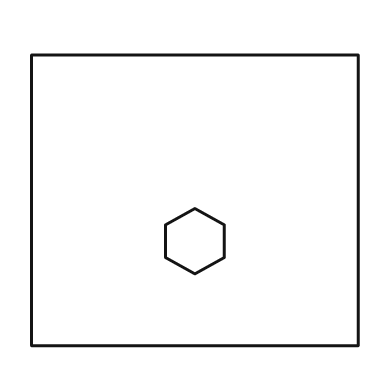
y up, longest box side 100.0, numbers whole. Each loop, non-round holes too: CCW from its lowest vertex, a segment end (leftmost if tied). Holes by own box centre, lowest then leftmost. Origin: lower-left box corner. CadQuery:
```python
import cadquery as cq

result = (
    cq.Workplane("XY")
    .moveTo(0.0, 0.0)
    .lineTo(100.0, 0.0)
    .lineTo(100.0, 89.0)
    .lineTo(0.0, 89.0)
    .close()
    .moveTo(50.0, 22.0)
    .lineTo(59.0, 27.0)
    .lineTo(59.0, 37.0)
    .lineTo(50.0, 42.0)
    .lineTo(41.0, 37.0)
    .lineTo(41.0, 27.0)
    .close()
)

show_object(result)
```